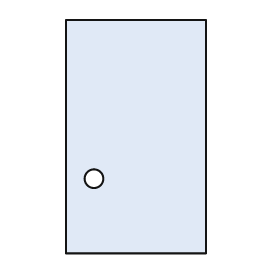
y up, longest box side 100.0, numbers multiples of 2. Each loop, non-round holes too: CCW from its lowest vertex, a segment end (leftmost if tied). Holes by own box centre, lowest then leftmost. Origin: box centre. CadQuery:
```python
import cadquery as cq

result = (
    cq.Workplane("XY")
    .moveTo(-30.0, -50.0)
    .lineTo(30.0, -50.0)
    .lineTo(30.0, 50.0)
    .lineTo(-30.0, 50.0)
    .close()
    .moveTo(-18.0, -18.0)
    .circle(4.0)
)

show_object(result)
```